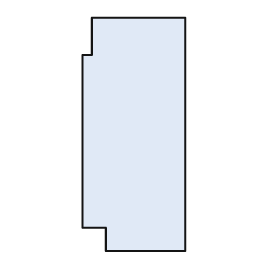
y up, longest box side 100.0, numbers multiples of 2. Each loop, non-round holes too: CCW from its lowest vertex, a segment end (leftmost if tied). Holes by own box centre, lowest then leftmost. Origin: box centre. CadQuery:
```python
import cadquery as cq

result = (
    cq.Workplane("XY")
    .moveTo(-12.0, -50.0)
    .lineTo(22.0, -50.0)
    .lineTo(22.0, 50.0)
    .lineTo(-18.0, 50.0)
    .lineTo(-18.0, 34.0)
    .lineTo(-22.0, 34.0)
    .lineTo(-22.0, -40.0)
    .lineTo(-12.0, -40.0)
    .close()
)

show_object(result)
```